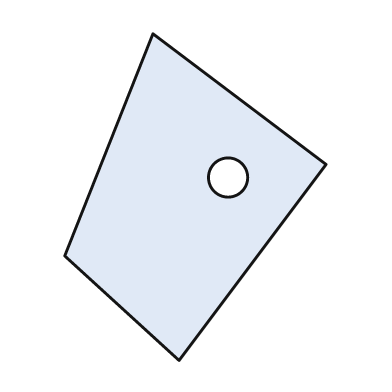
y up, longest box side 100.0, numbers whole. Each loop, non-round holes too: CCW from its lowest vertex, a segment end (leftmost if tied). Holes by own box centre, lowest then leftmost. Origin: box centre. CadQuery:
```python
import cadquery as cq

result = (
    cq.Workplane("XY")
    .moveTo(-5.0, -50.0)
    .lineTo(40.0, 10.0)
    .lineTo(-13.0, 50.0)
    .lineTo(-40.0, -18.0)
    .close()
    .moveTo(10.0, 6.0)
    .circle(6.0)
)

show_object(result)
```